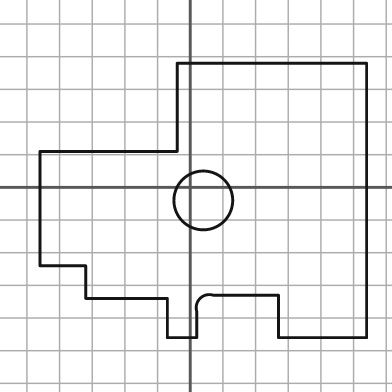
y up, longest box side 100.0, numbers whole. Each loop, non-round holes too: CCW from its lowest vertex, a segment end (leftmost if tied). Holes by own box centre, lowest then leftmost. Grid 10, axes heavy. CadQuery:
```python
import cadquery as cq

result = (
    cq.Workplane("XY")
    .moveTo(-7.0, -46.0)
    .lineTo(2.0, -46.0)
    .lineTo(2.0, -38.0)
    .threePointArc((3.0, -34.0), (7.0, -33.0))
    .lineTo(27.0, -33.0)
    .lineTo(27.0, -46.0)
    .lineTo(54.0, -46.0)
    .lineTo(54.0, 38.0)
    .lineTo(-4.0, 38.0)
    .lineTo(-4.0, 11.0)
    .lineTo(-46.0, 11.0)
    .lineTo(-46.0, -24.0)
    .lineTo(-32.0, -24.0)
    .lineTo(-32.0, -34.0)
    .lineTo(-7.0, -34.0)
    .close()
    .moveTo(4.0, -4.0)
    .circle(9.0)
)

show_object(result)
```